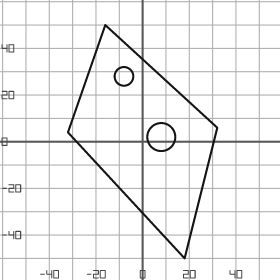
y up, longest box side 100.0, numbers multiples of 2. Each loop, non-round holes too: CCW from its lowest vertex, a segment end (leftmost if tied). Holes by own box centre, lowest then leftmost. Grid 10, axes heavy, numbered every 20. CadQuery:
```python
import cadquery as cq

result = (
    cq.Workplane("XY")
    .moveTo(18.0, -50.0)
    .lineTo(32.0, 6.0)
    .lineTo(-16.0, 50.0)
    .lineTo(-32.0, 4.0)
    .close()
    .moveTo(8.0, 2.0)
    .circle(6.0)
    .moveTo(-8.0, 28.0)
    .circle(4.0)
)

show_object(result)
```